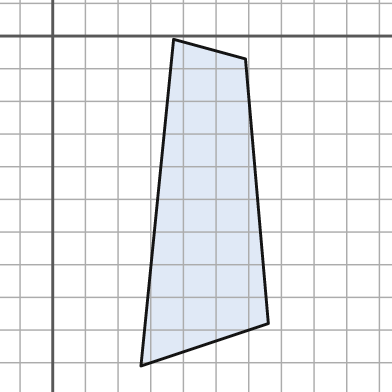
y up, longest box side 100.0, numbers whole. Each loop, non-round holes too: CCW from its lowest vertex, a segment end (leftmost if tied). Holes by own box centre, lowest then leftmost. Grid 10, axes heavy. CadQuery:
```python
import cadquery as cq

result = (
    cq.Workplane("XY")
    .moveTo(27.0, -101.0)
    .lineTo(66.0, -88.0)
    .lineTo(59.0, -7.0)
    .lineTo(37.0, -1.0)
    .close()
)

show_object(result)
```